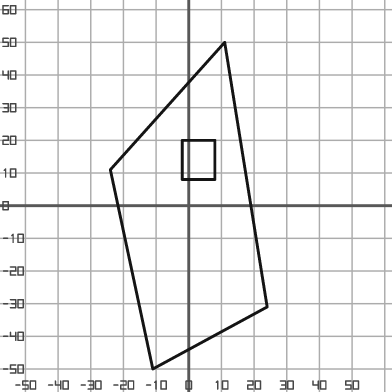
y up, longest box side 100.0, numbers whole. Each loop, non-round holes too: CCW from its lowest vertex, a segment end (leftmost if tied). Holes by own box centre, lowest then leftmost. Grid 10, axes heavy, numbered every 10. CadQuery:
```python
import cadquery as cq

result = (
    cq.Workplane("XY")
    .moveTo(-11.0, -50.0)
    .lineTo(24.0, -31.0)
    .lineTo(11.0, 50.0)
    .lineTo(-24.0, 11.0)
    .close()
    .moveTo(-2.0, 8.0)
    .lineTo(8.0, 8.0)
    .lineTo(8.0, 20.0)
    .lineTo(-2.0, 20.0)
    .close()
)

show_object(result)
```